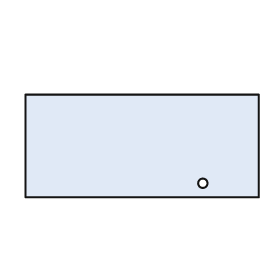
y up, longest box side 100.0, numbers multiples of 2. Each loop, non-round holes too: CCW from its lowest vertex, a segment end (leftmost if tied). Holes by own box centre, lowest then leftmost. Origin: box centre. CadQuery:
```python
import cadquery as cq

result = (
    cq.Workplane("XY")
    .moveTo(-50.0, -22.0)
    .lineTo(50.0, -22.0)
    .lineTo(50.0, 22.0)
    .lineTo(-50.0, 22.0)
    .close()
    .moveTo(26.0, -16.0)
    .circle(2.0)
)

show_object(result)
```